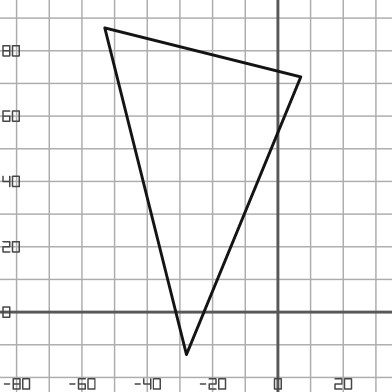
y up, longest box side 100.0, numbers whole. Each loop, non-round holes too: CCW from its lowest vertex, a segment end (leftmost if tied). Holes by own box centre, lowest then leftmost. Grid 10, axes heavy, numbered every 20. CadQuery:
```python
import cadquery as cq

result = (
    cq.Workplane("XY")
    .moveTo(-28.0, -13.0)
    .lineTo(7.0, 72.0)
    .lineTo(-53.0, 87.0)
    .close()
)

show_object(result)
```